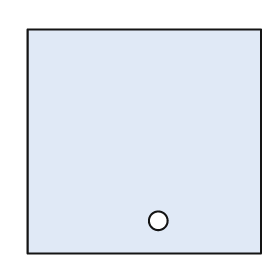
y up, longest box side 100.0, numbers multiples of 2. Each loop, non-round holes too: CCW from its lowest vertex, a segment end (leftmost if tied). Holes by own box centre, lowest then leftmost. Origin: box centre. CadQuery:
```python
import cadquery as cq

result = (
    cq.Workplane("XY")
    .moveTo(-50.0, -48.0)
    .lineTo(50.0, -48.0)
    .lineTo(50.0, 48.0)
    .lineTo(-50.0, 48.0)
    .close()
    .moveTo(6.0, -34.0)
    .circle(4.0)
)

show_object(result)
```